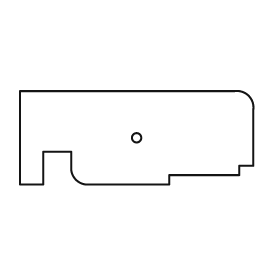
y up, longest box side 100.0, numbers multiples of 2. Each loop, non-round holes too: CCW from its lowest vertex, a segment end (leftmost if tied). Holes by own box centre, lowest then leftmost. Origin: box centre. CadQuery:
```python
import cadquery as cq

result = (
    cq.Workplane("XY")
    .moveTo(-50.0, -20.0)
    .lineTo(-40.0, -20.0)
    .lineTo(-40.0, -6.0)
    .lineTo(-28.0, -6.0)
    .lineTo(-28.0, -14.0)
    .threePointArc((-26.0, -18.0), (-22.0, -20.0))
    .lineTo(14.0, -20.0)
    .lineTo(14.0, -16.0)
    .lineTo(44.0, -16.0)
    .lineTo(44.0, -12.0)
    .lineTo(50.0, -12.0)
    .lineTo(50.0, 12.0)
    .threePointArc((48.0, 18.0), (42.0, 20.0))
    .lineTo(-50.0, 20.0)
    .close()
    .moveTo(0.0, 0.0)
    .circle(2.0)
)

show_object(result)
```